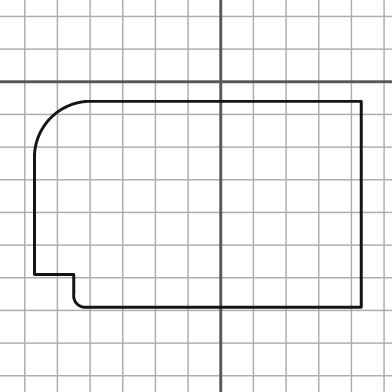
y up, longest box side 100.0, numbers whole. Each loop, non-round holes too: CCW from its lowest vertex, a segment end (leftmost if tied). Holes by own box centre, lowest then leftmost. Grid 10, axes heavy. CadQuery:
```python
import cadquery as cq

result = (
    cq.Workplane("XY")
    .moveTo(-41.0, -69.0)
    .lineTo(43.0, -69.0)
    .lineTo(43.0, -6.0)
    .lineTo(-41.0, -6.0)
    .threePointArc((-52.0, -11.0), (-57.0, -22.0))
    .lineTo(-57.0, -59.0)
    .lineTo(-45.0, -59.0)
    .lineTo(-45.0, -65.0)
    .threePointArc((-44.0, -68.0), (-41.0, -69.0))
    .close()
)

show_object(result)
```